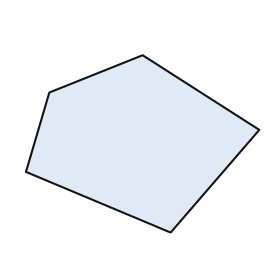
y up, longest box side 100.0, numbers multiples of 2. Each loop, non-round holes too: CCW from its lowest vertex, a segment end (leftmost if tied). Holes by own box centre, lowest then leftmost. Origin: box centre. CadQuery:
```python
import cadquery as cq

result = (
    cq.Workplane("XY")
    .moveTo(12.0, -38.0)
    .lineTo(50.0, 6.0)
    .lineTo(0.0, 38.0)
    .lineTo(-40.0, 22.0)
    .lineTo(-50.0, -12.0)
    .close()
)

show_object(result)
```